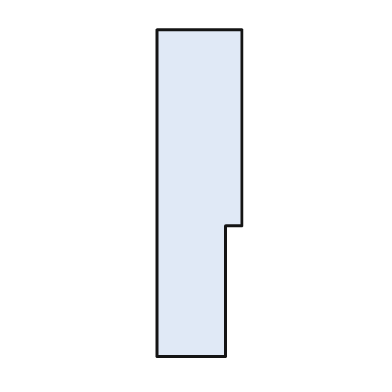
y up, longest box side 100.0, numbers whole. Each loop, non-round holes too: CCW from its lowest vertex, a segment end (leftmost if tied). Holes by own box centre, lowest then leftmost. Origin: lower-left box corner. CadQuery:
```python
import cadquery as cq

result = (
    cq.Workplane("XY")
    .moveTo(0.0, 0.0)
    .lineTo(21.0, 0.0)
    .lineTo(21.0, 40.0)
    .lineTo(26.0, 40.0)
    .lineTo(26.0, 100.0)
    .lineTo(0.0, 100.0)
    .close()
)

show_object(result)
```